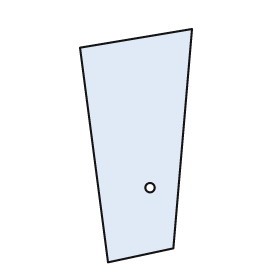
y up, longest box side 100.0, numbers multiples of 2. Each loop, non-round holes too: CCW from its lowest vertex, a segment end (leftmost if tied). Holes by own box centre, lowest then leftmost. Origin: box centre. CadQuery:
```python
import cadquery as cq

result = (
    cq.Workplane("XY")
    .moveTo(-12.0, -50.0)
    .lineTo(16.0, -44.0)
    .lineTo(24.0, 50.0)
    .lineTo(-24.0, 42.0)
    .close()
    .moveTo(6.0, -18.0)
    .circle(2.0)
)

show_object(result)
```